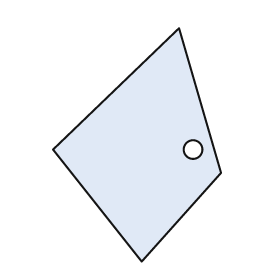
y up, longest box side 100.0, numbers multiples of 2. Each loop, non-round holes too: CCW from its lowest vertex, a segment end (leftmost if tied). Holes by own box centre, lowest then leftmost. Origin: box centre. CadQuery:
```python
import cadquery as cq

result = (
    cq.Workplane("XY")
    .moveTo(2.0, -50.0)
    .lineTo(36.0, -12.0)
    .lineTo(18.0, 50.0)
    .lineTo(-36.0, -2.0)
    .close()
    .moveTo(24.0, -2.0)
    .circle(4.0)
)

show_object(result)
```